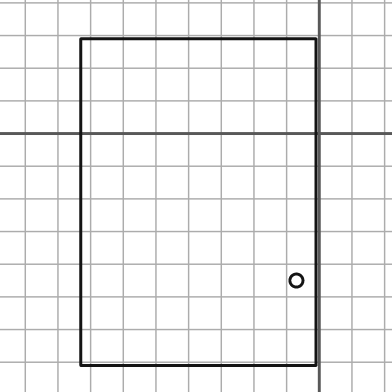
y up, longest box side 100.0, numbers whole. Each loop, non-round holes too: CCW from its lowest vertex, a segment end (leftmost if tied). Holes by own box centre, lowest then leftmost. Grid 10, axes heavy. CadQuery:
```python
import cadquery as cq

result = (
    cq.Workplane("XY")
    .moveTo(-73.0, -71.0)
    .lineTo(-1.0, -71.0)
    .lineTo(-1.0, 29.0)
    .lineTo(-73.0, 29.0)
    .close()
    .moveTo(-7.0, -45.0)
    .circle(2.0)
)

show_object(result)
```